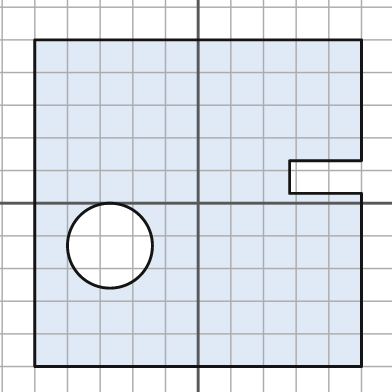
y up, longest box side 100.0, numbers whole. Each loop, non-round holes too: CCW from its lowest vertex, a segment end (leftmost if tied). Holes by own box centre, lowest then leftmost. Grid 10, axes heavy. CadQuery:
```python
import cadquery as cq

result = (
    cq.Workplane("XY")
    .moveTo(-50.0, -50.0)
    .lineTo(50.0, -50.0)
    .lineTo(50.0, 3.0)
    .lineTo(28.0, 3.0)
    .lineTo(28.0, 13.0)
    .lineTo(50.0, 13.0)
    .lineTo(50.0, 50.0)
    .lineTo(-50.0, 50.0)
    .close()
    .moveTo(-27.0, -13.0)
    .circle(13.0)
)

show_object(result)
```